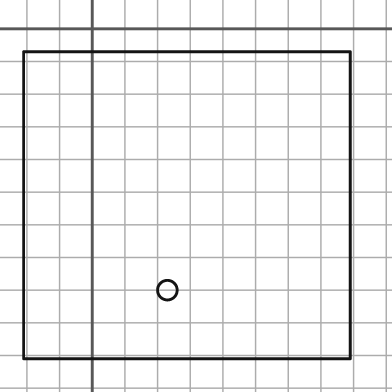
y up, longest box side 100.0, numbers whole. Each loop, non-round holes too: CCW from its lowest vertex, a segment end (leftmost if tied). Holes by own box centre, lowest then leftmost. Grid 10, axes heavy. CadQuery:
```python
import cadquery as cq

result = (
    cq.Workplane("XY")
    .moveTo(-21.0, -101.0)
    .lineTo(79.0, -101.0)
    .lineTo(79.0, -7.0)
    .lineTo(-21.0, -7.0)
    .close()
    .moveTo(23.0, -80.0)
    .circle(3.0)
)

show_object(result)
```